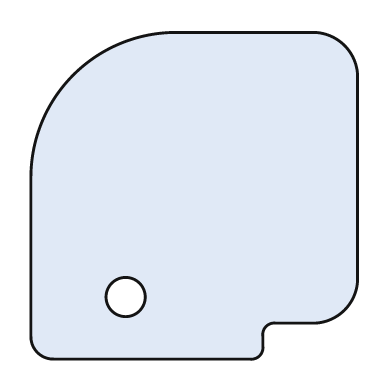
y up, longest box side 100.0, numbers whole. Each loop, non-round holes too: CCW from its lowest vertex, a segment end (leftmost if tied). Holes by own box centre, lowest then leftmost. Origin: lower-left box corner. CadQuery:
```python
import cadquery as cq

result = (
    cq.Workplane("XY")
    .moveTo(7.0, 0.0)
    .lineTo(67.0, 0.0)
    .threePointArc((70.0, 1.0), (71.0, 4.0))
    .lineTo(71.0, 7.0)
    .threePointArc((72.0, 10.0), (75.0, 11.0))
    .lineTo(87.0, 11.0)
    .threePointArc((96.0, 15.0), (100.0, 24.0))
    .lineTo(100.0, 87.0)
    .threePointArc((96.0, 96.0), (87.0, 100.0))
    .lineTo(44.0, 100.0)
    .threePointArc((13.0, 87.0), (0.0, 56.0))
    .lineTo(0.0, 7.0)
    .threePointArc((2.0, 2.0), (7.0, 0.0))
    .close()
    .moveTo(29.0, 19.0)
    .circle(6.0)
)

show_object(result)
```